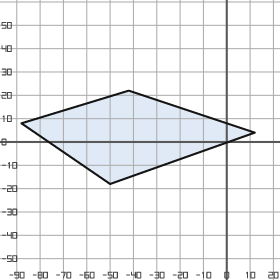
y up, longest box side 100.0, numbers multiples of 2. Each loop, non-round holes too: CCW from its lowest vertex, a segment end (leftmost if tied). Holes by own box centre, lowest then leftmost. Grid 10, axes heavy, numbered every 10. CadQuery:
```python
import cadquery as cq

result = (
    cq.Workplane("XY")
    .moveTo(-50.0, -18.0)
    .lineTo(12.0, 4.0)
    .lineTo(-42.0, 22.0)
    .lineTo(-88.0, 8.0)
    .close()
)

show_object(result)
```